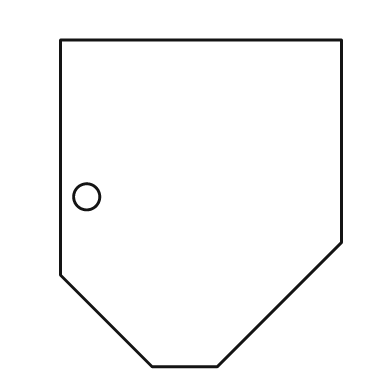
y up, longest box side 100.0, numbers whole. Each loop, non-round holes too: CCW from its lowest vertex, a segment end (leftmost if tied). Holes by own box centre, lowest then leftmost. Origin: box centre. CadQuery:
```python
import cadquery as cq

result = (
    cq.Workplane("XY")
    .moveTo(-15.0, -50.0)
    .lineTo(5.0, -50.0)
    .lineTo(43.0, -12.0)
    .lineTo(43.0, 50.0)
    .lineTo(-43.0, 50.0)
    .lineTo(-43.0, -22.0)
    .close()
    .moveTo(-35.0, 2.0)
    .circle(4.0)
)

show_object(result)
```